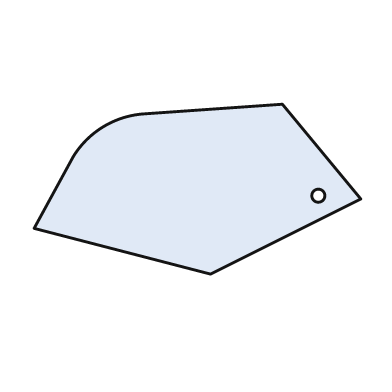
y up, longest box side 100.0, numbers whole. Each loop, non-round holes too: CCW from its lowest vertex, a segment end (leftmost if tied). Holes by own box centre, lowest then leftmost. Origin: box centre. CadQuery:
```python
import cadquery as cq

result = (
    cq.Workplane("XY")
    .moveTo(4.0, -26.0)
    .lineTo(50.0, -3.0)
    .lineTo(26.0, 26.0)
    .lineTo(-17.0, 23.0)
    .threePointArc((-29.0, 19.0), (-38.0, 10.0))
    .lineTo(-50.0, -12.0)
    .close()
    .moveTo(37.0, -2.0)
    .circle(2.0)
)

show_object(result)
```